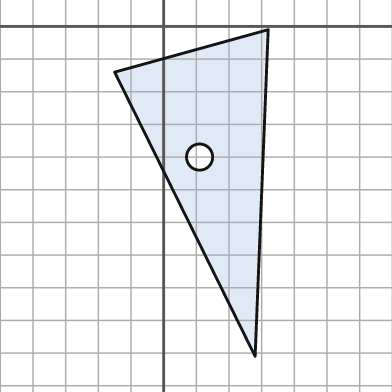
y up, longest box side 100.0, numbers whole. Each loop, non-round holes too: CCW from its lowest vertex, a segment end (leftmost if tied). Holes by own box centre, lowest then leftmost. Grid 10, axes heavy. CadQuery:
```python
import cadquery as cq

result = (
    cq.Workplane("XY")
    .moveTo(28.0, -101.0)
    .lineTo(32.0, -1.0)
    .lineTo(-15.0, -14.0)
    .close()
    .moveTo(11.0, -40.0)
    .circle(4.0)
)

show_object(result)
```